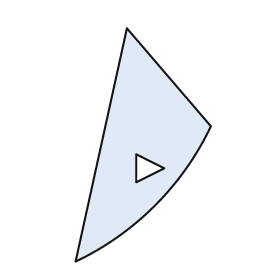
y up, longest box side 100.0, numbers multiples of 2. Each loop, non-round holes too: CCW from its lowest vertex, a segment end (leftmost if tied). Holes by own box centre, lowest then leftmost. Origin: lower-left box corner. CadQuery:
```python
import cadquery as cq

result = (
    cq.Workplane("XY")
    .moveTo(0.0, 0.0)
    .threePointArc((34.0, 24.0), (58.0, 58.0))
    .lineTo(22.0, 100.0)
    .close()
    .moveTo(26.0, 34.0)
    .lineTo(38.0, 40.0)
    .lineTo(26.0, 46.0)
    .close()
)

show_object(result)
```